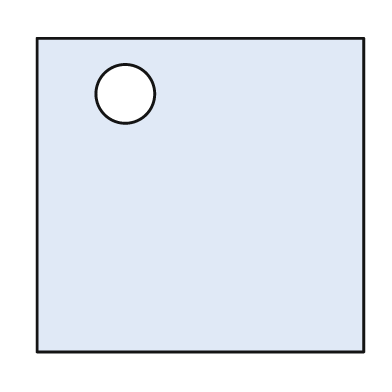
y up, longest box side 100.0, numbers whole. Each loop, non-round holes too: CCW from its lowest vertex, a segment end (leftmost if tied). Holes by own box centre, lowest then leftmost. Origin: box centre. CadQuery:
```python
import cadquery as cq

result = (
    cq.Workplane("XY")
    .moveTo(-50.0, -48.0)
    .lineTo(50.0, -48.0)
    .lineTo(50.0, 48.0)
    .lineTo(-50.0, 48.0)
    .close()
    .moveTo(-23.0, 31.0)
    .circle(9.0)
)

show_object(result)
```